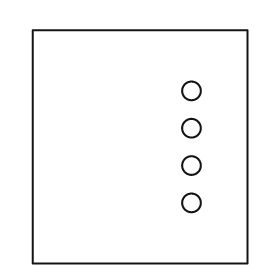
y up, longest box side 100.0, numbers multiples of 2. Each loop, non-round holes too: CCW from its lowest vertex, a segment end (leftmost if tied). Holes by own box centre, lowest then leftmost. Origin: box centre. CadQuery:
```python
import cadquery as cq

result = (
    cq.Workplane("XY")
    .moveTo(-46.0, -50.0)
    .lineTo(46.0, -50.0)
    .lineTo(46.0, 50.0)
    .lineTo(-46.0, 50.0)
    .close()
    .moveTo(22.0, -24.0)
    .circle(4.0)
    .moveTo(22.0, -8.0)
    .circle(4.0)
    .moveTo(22.0, 8.0)
    .circle(4.0)
    .moveTo(22.0, 24.0)
    .circle(4.0)
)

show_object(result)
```